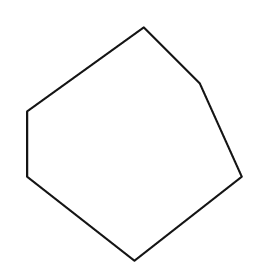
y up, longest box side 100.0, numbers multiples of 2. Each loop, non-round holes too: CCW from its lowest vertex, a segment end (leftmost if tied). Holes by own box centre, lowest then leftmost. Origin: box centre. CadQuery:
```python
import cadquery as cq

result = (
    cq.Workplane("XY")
    .moveTo(0.0, -50.0)
    .lineTo(46.0, -14.0)
    .lineTo(28.0, 26.0)
    .lineTo(4.0, 50.0)
    .lineTo(-46.0, 14.0)
    .lineTo(-46.0, -14.0)
    .close()
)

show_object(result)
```